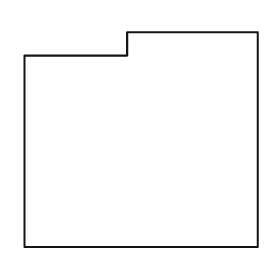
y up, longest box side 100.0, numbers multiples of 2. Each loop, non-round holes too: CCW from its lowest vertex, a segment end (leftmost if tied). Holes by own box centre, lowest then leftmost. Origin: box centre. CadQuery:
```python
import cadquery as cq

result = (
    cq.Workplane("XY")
    .moveTo(-50.0, -46.0)
    .lineTo(50.0, -46.0)
    .lineTo(50.0, 46.0)
    .lineTo(-6.0, 46.0)
    .lineTo(-6.0, 36.0)
    .lineTo(-50.0, 36.0)
    .close()
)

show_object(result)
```